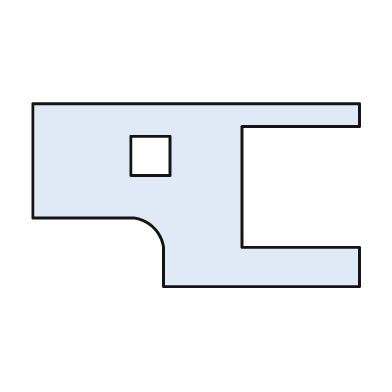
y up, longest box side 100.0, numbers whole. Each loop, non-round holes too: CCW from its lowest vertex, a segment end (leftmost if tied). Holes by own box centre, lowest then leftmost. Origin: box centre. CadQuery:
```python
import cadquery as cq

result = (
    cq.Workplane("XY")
    .moveTo(-10.0, -28.0)
    .lineTo(50.0, -28.0)
    .lineTo(50.0, -16.0)
    .lineTo(14.0, -16.0)
    .lineTo(14.0, 21.0)
    .lineTo(50.0, 21.0)
    .lineTo(50.0, 28.0)
    .lineTo(-50.0, 28.0)
    .lineTo(-50.0, -7.0)
    .lineTo(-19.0, -7.0)
    .threePointArc((-13.0, -10.0), (-10.0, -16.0))
    .close()
    .moveTo(-20.0, 6.0)
    .lineTo(-8.0, 6.0)
    .lineTo(-8.0, 18.0)
    .lineTo(-20.0, 18.0)
    .close()
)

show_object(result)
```